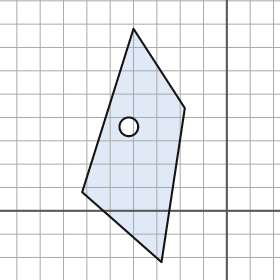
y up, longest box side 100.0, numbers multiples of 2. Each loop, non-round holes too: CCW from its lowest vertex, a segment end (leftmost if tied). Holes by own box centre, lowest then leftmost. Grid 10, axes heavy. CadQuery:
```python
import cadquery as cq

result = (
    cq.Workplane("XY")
    .moveTo(-28.0, -22.0)
    .lineTo(-18.0, 44.0)
    .lineTo(-40.0, 78.0)
    .lineTo(-62.0, 8.0)
    .close()
    .moveTo(-42.0, 36.0)
    .circle(4.0)
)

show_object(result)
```